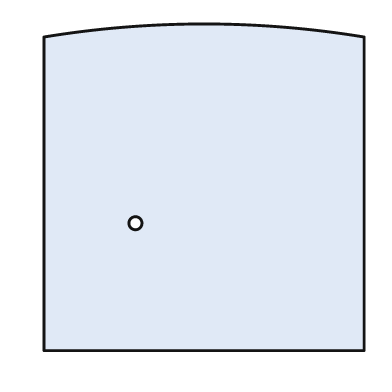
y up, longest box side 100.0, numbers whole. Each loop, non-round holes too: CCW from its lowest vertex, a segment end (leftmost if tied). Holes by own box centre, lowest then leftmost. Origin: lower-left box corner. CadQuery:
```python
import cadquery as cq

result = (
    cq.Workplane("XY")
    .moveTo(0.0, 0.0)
    .lineTo(98.0, 0.0)
    .lineTo(98.0, 96.0)
    .threePointArc((49.0, 100.0), (0.0, 96.0))
    .close()
    .moveTo(28.0, 39.0)
    .circle(2.0)
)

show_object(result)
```